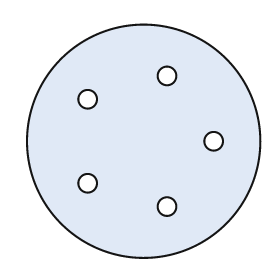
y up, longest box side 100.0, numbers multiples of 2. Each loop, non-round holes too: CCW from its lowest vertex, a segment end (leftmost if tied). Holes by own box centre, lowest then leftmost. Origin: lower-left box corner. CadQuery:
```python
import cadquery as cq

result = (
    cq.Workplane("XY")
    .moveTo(50.0, 50.0)
    .circle(50.0)
    .moveTo(60.0, 22.0)
    .circle(4.0)
    .moveTo(26.0, 32.0)
    .circle(4.0)
    .moveTo(80.0, 50.0)
    .circle(4.0)
    .moveTo(26.0, 68.0)
    .circle(4.0)
    .moveTo(60.0, 78.0)
    .circle(4.0)
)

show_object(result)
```